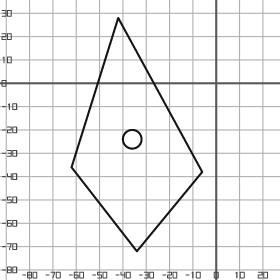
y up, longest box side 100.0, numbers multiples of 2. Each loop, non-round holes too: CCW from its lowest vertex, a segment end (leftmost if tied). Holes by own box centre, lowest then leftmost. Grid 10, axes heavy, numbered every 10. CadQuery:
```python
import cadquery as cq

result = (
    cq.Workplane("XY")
    .moveTo(-34.0, -72.0)
    .lineTo(-6.0, -38.0)
    .lineTo(-42.0, 28.0)
    .lineTo(-62.0, -36.0)
    .close()
    .moveTo(-36.0, -24.0)
    .circle(4.0)
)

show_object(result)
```